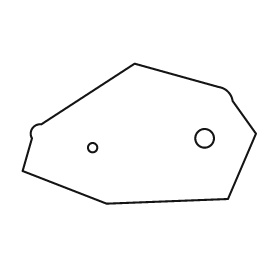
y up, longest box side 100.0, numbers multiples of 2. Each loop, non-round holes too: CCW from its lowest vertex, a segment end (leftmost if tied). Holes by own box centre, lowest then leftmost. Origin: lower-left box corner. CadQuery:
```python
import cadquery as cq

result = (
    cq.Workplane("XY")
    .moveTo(36.0, 0.0)
    .lineTo(88.0, 2.0)
    .lineTo(100.0, 30.0)
    .lineTo(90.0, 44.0)
    .threePointArc((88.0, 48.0), (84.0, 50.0))
    .lineTo(48.0, 60.0)
    .lineTo(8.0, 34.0)
    .threePointArc((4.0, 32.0), (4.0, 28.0))
    .lineTo(0.0, 14.0)
    .close()
    .moveTo(30.0, 24.0)
    .circle(2.0)
    .moveTo(78.0, 28.0)
    .circle(4.0)
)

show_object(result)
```